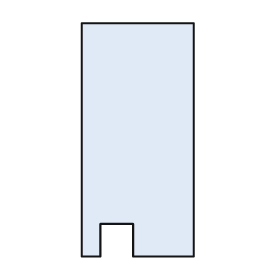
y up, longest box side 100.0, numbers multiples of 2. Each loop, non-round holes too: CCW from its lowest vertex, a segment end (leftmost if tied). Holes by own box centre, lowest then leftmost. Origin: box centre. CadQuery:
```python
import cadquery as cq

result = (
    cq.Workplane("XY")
    .moveTo(-24.0, -50.0)
    .lineTo(-16.0, -50.0)
    .lineTo(-16.0, -36.0)
    .lineTo(-2.0, -36.0)
    .lineTo(-2.0, -50.0)
    .lineTo(24.0, -50.0)
    .lineTo(24.0, 50.0)
    .lineTo(-24.0, 50.0)
    .close()
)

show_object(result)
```